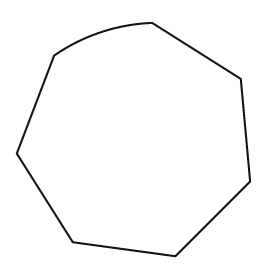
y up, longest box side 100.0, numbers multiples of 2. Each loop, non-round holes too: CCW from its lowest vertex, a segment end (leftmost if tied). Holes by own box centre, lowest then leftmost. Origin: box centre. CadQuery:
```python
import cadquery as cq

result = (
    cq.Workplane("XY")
    .moveTo(18.0, -50.0)
    .lineTo(50.0, -18.0)
    .lineTo(46.0, 26.0)
    .lineTo(8.0, 50.0)
    .threePointArc((-14.0, 46.0), (-34.0, 36.0))
    .lineTo(-50.0, -6.0)
    .lineTo(-26.0, -44.0)
    .close()
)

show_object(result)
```